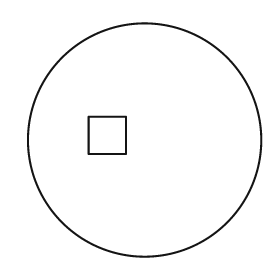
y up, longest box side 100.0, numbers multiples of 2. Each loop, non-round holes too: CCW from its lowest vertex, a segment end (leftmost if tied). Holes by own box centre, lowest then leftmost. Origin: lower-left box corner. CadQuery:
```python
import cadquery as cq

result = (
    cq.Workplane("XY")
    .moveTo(50.0, 50.0)
    .circle(50.0)
    .moveTo(26.0, 44.0)
    .lineTo(42.0, 44.0)
    .lineTo(42.0, 60.0)
    .lineTo(26.0, 60.0)
    .close()
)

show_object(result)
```